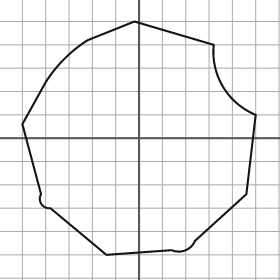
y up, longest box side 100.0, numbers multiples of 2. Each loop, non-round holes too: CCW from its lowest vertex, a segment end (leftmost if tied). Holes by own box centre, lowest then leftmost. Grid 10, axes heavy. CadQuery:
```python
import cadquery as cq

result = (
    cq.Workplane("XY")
    .moveTo(-14.0, -50.0)
    .lineTo(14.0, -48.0)
    .threePointArc((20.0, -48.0), (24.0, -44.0))
    .lineTo(46.0, -24.0)
    .lineTo(50.0, 10.0)
    .threePointArc((36.0, 22.0), (32.0, 40.0))
    .lineTo(-2.0, 50.0)
    .lineTo(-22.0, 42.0)
    .threePointArc((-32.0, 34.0), (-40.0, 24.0))
    .lineTo(-50.0, 6.0)
    .lineTo(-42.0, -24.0)
    .threePointArc((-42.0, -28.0), (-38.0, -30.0))
    .close()
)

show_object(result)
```